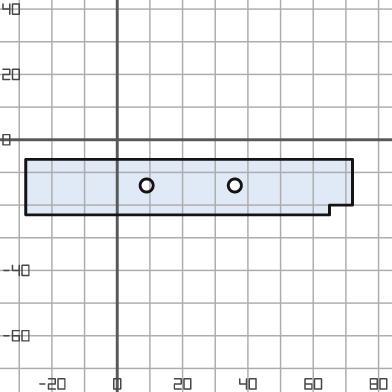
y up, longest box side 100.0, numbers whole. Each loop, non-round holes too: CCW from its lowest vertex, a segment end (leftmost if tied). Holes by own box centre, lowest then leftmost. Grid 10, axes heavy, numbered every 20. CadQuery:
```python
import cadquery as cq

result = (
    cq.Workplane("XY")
    .moveTo(-28.0, -23.0)
    .lineTo(65.0, -23.0)
    .lineTo(65.0, -20.0)
    .lineTo(72.0, -20.0)
    .lineTo(72.0, -6.0)
    .lineTo(-28.0, -6.0)
    .close()
    .moveTo(9.0, -14.0)
    .circle(2.0)
    .moveTo(36.0, -14.0)
    .circle(2.0)
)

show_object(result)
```